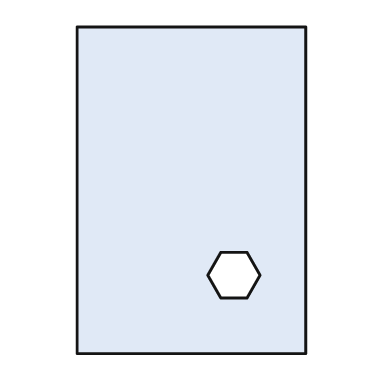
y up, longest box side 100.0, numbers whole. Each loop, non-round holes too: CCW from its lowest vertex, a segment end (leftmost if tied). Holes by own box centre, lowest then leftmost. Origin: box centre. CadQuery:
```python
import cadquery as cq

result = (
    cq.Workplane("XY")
    .moveTo(-35.0, -50.0)
    .lineTo(35.0, -50.0)
    .lineTo(35.0, 50.0)
    .lineTo(-35.0, 50.0)
    .close()
    .moveTo(9.0, -33.0)
    .lineTo(17.0, -33.0)
    .lineTo(21.0, -26.0)
    .lineTo(17.0, -19.0)
    .lineTo(9.0, -19.0)
    .lineTo(5.0, -26.0)
    .close()
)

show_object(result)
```